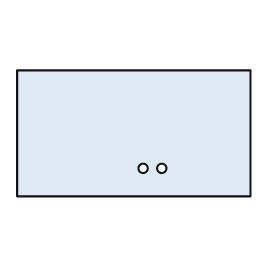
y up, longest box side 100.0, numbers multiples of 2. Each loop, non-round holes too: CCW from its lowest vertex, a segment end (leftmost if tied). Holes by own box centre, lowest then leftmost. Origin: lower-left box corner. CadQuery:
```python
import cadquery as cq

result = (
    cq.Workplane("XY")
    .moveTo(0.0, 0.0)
    .lineTo(100.0, 0.0)
    .lineTo(100.0, 54.0)
    .lineTo(0.0, 54.0)
    .close()
    .moveTo(54.0, 12.0)
    .circle(2.0)
    .moveTo(62.0, 12.0)
    .circle(2.0)
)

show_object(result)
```